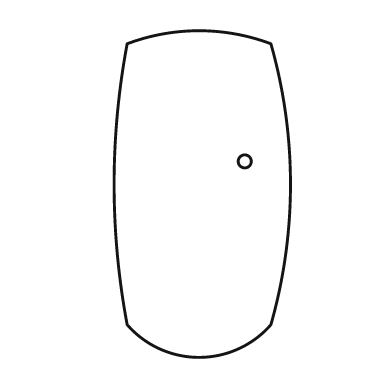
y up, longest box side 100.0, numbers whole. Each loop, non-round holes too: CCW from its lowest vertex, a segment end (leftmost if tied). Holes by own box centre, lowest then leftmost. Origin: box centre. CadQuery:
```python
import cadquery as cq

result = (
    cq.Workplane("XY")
    .moveTo(-23.0, -40.0)
    .threePointArc((-1.0, -50.0), (21.0, -40.0))
    .threePointArc((27.0, 3.0), (21.0, 46.0))
    .threePointArc((-1.0, 50.0), (-23.0, 46.0))
    .threePointArc((-27.0, 3.0), (-23.0, -40.0))
    .close()
    .moveTo(13.0, 10.0)
    .circle(2.0)
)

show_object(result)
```